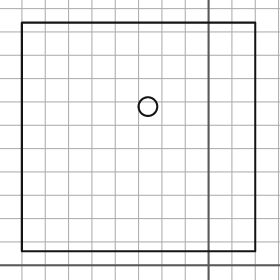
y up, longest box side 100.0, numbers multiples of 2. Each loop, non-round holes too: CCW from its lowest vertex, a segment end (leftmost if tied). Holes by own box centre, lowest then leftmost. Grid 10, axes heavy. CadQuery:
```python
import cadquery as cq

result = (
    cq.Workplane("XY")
    .moveTo(-80.0, 6.0)
    .lineTo(20.0, 6.0)
    .lineTo(20.0, 104.0)
    .lineTo(-80.0, 104.0)
    .close()
    .moveTo(-26.0, 68.0)
    .circle(4.0)
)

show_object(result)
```